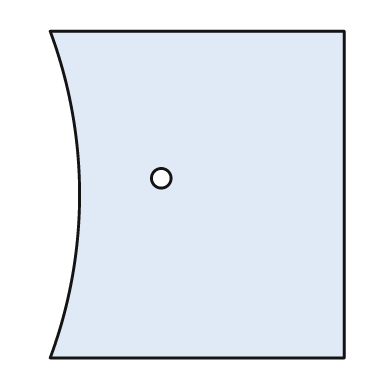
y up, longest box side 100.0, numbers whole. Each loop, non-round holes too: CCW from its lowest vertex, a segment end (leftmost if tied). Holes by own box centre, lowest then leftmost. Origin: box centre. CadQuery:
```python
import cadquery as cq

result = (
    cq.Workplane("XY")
    .moveTo(-45.0, -50.0)
    .lineTo(45.0, -50.0)
    .lineTo(45.0, 50.0)
    .lineTo(-45.0, 50.0)
    .threePointArc((-36.0, 0.0), (-45.0, -50.0))
    .close()
    .moveTo(-11.0, 5.0)
    .circle(3.0)
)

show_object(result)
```